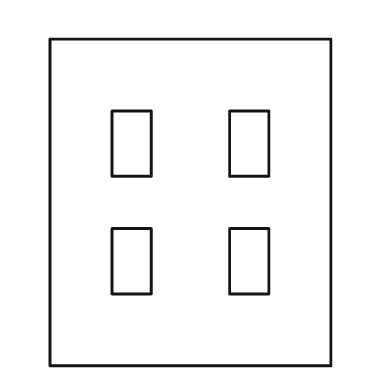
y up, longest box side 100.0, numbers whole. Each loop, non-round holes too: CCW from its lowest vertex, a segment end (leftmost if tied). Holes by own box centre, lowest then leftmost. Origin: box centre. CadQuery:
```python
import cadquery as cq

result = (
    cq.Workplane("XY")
    .moveTo(-43.0, -50.0)
    .lineTo(43.0, -50.0)
    .lineTo(43.0, 50.0)
    .lineTo(-43.0, 50.0)
    .close()
    .moveTo(-24.0, -28.0)
    .lineTo(-12.0, -28.0)
    .lineTo(-12.0, -8.0)
    .lineTo(-24.0, -8.0)
    .close()
    .moveTo(12.0, -28.0)
    .lineTo(24.0, -28.0)
    .lineTo(24.0, -8.0)
    .lineTo(12.0, -8.0)
    .close()
    .moveTo(-24.0, 8.0)
    .lineTo(-12.0, 8.0)
    .lineTo(-12.0, 28.0)
    .lineTo(-24.0, 28.0)
    .close()
    .moveTo(12.0, 8.0)
    .lineTo(24.0, 8.0)
    .lineTo(24.0, 28.0)
    .lineTo(12.0, 28.0)
    .close()
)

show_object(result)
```